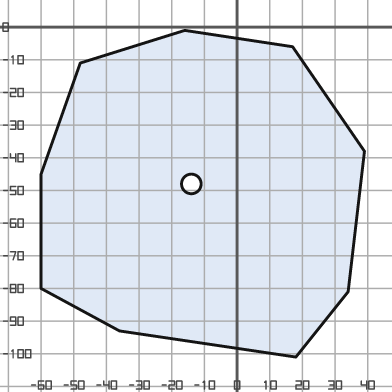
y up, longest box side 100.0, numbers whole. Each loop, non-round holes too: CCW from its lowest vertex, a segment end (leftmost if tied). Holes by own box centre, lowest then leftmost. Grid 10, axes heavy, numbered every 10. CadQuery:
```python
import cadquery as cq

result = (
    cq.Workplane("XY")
    .moveTo(18.0, -101.0)
    .lineTo(34.0, -81.0)
    .lineTo(39.0, -38.0)
    .lineTo(17.0, -6.0)
    .lineTo(-16.0, -1.0)
    .lineTo(-48.0, -11.0)
    .lineTo(-60.0, -45.0)
    .lineTo(-60.0, -80.0)
    .lineTo(-36.0, -93.0)
    .close()
    .moveTo(-14.0, -48.0)
    .circle(3.0)
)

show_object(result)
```